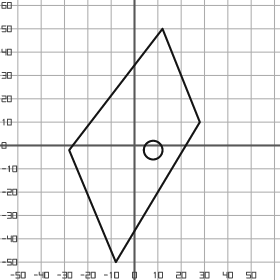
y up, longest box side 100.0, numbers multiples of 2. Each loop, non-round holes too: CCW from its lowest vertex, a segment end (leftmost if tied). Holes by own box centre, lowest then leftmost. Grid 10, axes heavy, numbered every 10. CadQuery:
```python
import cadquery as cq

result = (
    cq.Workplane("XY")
    .moveTo(-8.0, -50.0)
    .lineTo(28.0, 10.0)
    .lineTo(12.0, 50.0)
    .lineTo(-28.0, -2.0)
    .close()
    .moveTo(8.0, -2.0)
    .circle(4.0)
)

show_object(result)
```